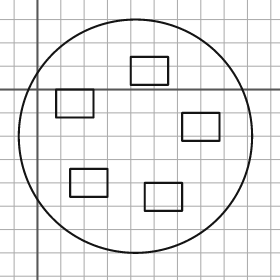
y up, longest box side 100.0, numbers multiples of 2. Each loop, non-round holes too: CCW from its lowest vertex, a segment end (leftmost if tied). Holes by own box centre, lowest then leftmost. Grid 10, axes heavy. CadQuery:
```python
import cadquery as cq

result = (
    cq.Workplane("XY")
    .moveTo(42.0, -20.0)
    .circle(50.0)
    .moveTo(46.0, -52.0)
    .lineTo(62.0, -52.0)
    .lineTo(62.0, -40.0)
    .lineTo(46.0, -40.0)
    .close()
    .moveTo(14.0, -46.0)
    .lineTo(30.0, -46.0)
    .lineTo(30.0, -34.0)
    .lineTo(14.0, -34.0)
    .close()
    .moveTo(62.0, -22.0)
    .lineTo(78.0, -22.0)
    .lineTo(78.0, -10.0)
    .lineTo(62.0, -10.0)
    .close()
    .moveTo(8.0, -12.0)
    .lineTo(24.0, -12.0)
    .lineTo(24.0, 0.0)
    .lineTo(8.0, 0.0)
    .close()
    .moveTo(40.0, 2.0)
    .lineTo(56.0, 2.0)
    .lineTo(56.0, 14.0)
    .lineTo(40.0, 14.0)
    .close()
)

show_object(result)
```